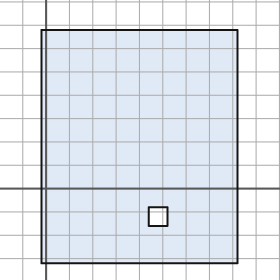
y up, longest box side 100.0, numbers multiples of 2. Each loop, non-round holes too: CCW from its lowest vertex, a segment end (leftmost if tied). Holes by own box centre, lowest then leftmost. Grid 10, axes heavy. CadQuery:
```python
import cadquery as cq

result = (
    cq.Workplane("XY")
    .moveTo(-2.0, -32.0)
    .lineTo(82.0, -32.0)
    .lineTo(82.0, 68.0)
    .lineTo(-2.0, 68.0)
    .close()
    .moveTo(44.0, -16.0)
    .lineTo(52.0, -16.0)
    .lineTo(52.0, -8.0)
    .lineTo(44.0, -8.0)
    .close()
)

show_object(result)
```